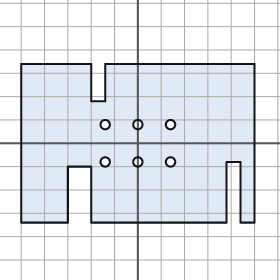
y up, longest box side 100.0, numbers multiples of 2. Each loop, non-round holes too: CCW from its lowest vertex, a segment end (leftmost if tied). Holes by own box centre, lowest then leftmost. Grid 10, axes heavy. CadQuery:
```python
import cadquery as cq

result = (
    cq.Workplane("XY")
    .moveTo(-50.0, -34.0)
    .lineTo(-30.0, -34.0)
    .lineTo(-30.0, -10.0)
    .lineTo(-20.0, -10.0)
    .lineTo(-20.0, -34.0)
    .lineTo(38.0, -34.0)
    .lineTo(38.0, -8.0)
    .lineTo(44.0, -8.0)
    .lineTo(44.0, -34.0)
    .lineTo(50.0, -34.0)
    .lineTo(50.0, 34.0)
    .lineTo(-14.0, 34.0)
    .lineTo(-14.0, 18.0)
    .lineTo(-20.0, 18.0)
    .lineTo(-20.0, 34.0)
    .lineTo(-50.0, 34.0)
    .close()
    .moveTo(-14.0, -8.0)
    .circle(2.0)
    .moveTo(0.0, -8.0)
    .circle(2.0)
    .moveTo(14.0, -8.0)
    .circle(2.0)
    .moveTo(-14.0, 8.0)
    .circle(2.0)
    .moveTo(0.0, 8.0)
    .circle(2.0)
    .moveTo(14.0, 8.0)
    .circle(2.0)
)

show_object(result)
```